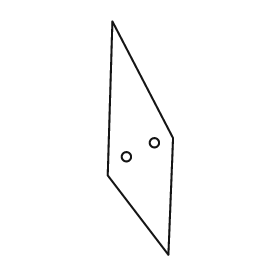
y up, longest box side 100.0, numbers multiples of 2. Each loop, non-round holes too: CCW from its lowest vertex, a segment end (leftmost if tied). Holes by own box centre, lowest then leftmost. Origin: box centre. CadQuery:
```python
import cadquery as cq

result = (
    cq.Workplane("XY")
    .moveTo(12.0, -50.0)
    .lineTo(14.0, 0.0)
    .lineTo(-12.0, 50.0)
    .lineTo(-14.0, -16.0)
    .close()
    .moveTo(-6.0, -8.0)
    .circle(2.0)
    .moveTo(6.0, -2.0)
    .circle(2.0)
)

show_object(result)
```